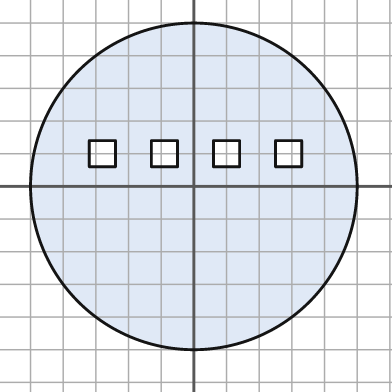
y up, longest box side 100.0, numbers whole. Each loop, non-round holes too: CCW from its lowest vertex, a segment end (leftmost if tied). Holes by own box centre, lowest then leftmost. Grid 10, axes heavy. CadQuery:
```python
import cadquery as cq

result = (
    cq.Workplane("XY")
    .moveTo(0.0, 0.0)
    .circle(50.0)
    .moveTo(-32.0, 6.0)
    .lineTo(-24.0, 6.0)
    .lineTo(-24.0, 14.0)
    .lineTo(-32.0, 14.0)
    .close()
    .moveTo(-13.0, 6.0)
    .lineTo(-5.0, 6.0)
    .lineTo(-5.0, 14.0)
    .lineTo(-13.0, 14.0)
    .close()
    .moveTo(6.0, 6.0)
    .lineTo(14.0, 6.0)
    .lineTo(14.0, 14.0)
    .lineTo(6.0, 14.0)
    .close()
    .moveTo(25.0, 6.0)
    .lineTo(33.0, 6.0)
    .lineTo(33.0, 14.0)
    .lineTo(25.0, 14.0)
    .close()
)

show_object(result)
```